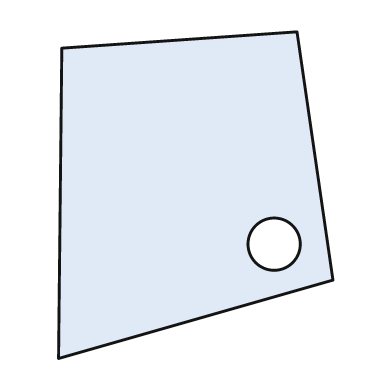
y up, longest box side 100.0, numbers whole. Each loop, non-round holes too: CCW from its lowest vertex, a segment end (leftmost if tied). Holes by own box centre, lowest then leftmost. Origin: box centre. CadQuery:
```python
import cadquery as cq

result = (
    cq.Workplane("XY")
    .moveTo(-42.0, -50.0)
    .lineTo(42.0, -26.0)
    .lineTo(31.0, 50.0)
    .lineTo(-41.0, 45.0)
    .close()
    .moveTo(24.0, -15.0)
    .circle(8.0)
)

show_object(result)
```